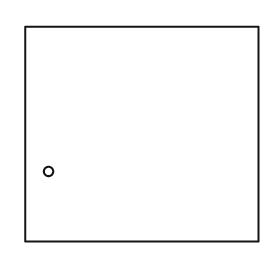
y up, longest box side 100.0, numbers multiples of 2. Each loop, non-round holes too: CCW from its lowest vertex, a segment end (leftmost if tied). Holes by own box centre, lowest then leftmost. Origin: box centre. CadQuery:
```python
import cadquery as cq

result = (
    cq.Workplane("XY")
    .moveTo(-50.0, -46.0)
    .lineTo(50.0, -46.0)
    .lineTo(50.0, 46.0)
    .lineTo(-50.0, 46.0)
    .close()
    .moveTo(-40.0, -16.0)
    .circle(2.0)
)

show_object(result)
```